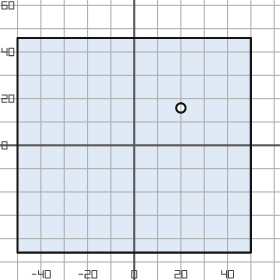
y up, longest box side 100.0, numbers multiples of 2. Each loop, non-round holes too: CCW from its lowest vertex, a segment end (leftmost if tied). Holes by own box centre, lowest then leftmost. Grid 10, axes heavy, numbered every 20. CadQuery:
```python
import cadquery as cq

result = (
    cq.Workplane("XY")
    .moveTo(-50.0, -46.0)
    .lineTo(50.0, -46.0)
    .lineTo(50.0, 46.0)
    .lineTo(-50.0, 46.0)
    .close()
    .moveTo(20.0, 16.0)
    .circle(2.0)
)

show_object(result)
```